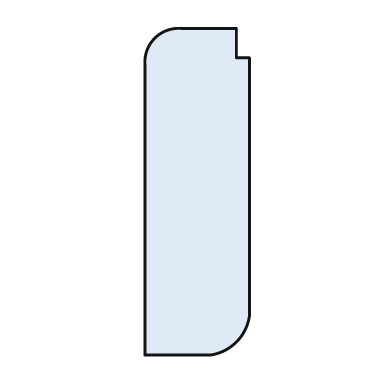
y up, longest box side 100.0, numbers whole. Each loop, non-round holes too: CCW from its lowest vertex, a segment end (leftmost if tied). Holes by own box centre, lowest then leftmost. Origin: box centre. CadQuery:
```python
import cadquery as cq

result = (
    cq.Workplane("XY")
    .moveTo(-16.0, -50.0)
    .lineTo(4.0, -50.0)
    .threePointArc((12.0, -46.0), (16.0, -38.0))
    .lineTo(16.0, 41.0)
    .lineTo(12.0, 41.0)
    .lineTo(12.0, 50.0)
    .lineTo(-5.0, 50.0)
    .threePointArc((-13.0, 47.0), (-16.0, 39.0))
    .close()
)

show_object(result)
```